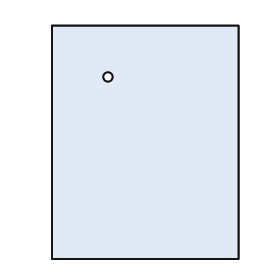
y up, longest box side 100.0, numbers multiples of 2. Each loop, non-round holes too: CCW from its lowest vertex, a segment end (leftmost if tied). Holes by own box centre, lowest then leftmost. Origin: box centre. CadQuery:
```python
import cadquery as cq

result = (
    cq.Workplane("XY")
    .moveTo(-40.0, -50.0)
    .lineTo(40.0, -50.0)
    .lineTo(40.0, 50.0)
    .lineTo(-40.0, 50.0)
    .close()
    .moveTo(-16.0, 28.0)
    .circle(2.0)
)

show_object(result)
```